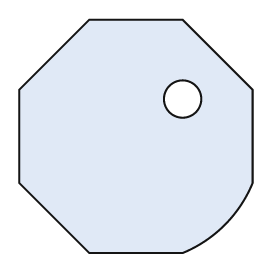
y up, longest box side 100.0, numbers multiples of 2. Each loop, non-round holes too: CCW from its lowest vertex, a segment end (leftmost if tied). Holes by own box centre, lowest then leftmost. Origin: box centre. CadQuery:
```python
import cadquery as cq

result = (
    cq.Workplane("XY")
    .moveTo(-20.0, -50.0)
    .lineTo(20.0, -50.0)
    .threePointArc((38.0, -38.0), (50.0, -20.0))
    .lineTo(50.0, 20.0)
    .lineTo(20.0, 50.0)
    .lineTo(-20.0, 50.0)
    .lineTo(-50.0, 20.0)
    .lineTo(-50.0, -20.0)
    .close()
    .moveTo(20.0, 16.0)
    .circle(8.0)
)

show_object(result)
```